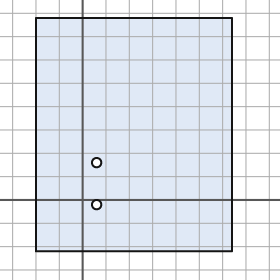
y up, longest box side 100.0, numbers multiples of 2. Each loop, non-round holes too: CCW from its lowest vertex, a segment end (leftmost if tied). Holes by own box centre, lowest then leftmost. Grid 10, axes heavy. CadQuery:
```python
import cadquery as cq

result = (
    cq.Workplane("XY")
    .moveTo(-20.0, -22.0)
    .lineTo(64.0, -22.0)
    .lineTo(64.0, 78.0)
    .lineTo(-20.0, 78.0)
    .close()
    .moveTo(6.0, -2.0)
    .circle(2.0)
    .moveTo(6.0, 16.0)
    .circle(2.0)
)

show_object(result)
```